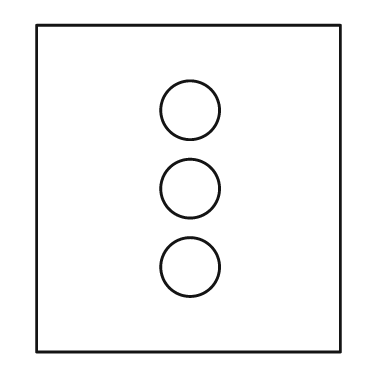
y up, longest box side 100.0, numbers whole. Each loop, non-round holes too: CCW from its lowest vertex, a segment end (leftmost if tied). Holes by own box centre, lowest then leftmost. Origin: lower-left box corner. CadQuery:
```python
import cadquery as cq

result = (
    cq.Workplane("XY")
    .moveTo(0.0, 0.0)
    .lineTo(93.0, 0.0)
    .lineTo(93.0, 100.0)
    .lineTo(0.0, 100.0)
    .close()
    .moveTo(47.0, 26.0)
    .circle(9.0)
    .moveTo(47.0, 50.0)
    .circle(9.0)
    .moveTo(47.0, 74.0)
    .circle(9.0)
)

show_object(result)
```